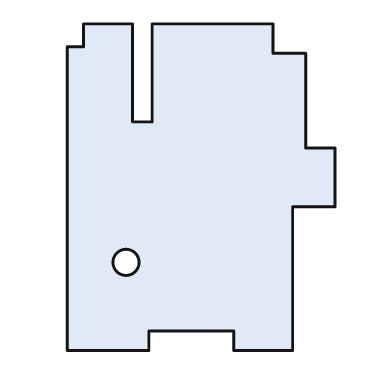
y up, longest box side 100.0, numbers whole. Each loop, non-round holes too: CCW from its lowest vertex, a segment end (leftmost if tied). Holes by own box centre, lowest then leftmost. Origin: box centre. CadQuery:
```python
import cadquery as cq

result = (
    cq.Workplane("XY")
    .moveTo(-41.0, -50.0)
    .lineTo(-16.0, -50.0)
    .lineTo(-16.0, -44.0)
    .lineTo(10.0, -44.0)
    .lineTo(10.0, -50.0)
    .lineTo(28.0, -50.0)
    .lineTo(28.0, -6.0)
    .lineTo(41.0, -6.0)
    .lineTo(41.0, 12.0)
    .lineTo(32.0, 12.0)
    .lineTo(32.0, 41.0)
    .lineTo(22.0, 41.0)
    .lineTo(22.0, 50.0)
    .lineTo(-15.0, 50.0)
    .lineTo(-15.0, 20.0)
    .lineTo(-21.0, 20.0)
    .lineTo(-21.0, 50.0)
    .lineTo(-36.0, 50.0)
    .lineTo(-36.0, 43.0)
    .lineTo(-41.0, 43.0)
    .close()
    .moveTo(-23.0, -23.0)
    .circle(4.0)
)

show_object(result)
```